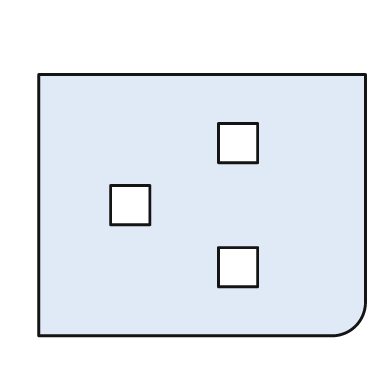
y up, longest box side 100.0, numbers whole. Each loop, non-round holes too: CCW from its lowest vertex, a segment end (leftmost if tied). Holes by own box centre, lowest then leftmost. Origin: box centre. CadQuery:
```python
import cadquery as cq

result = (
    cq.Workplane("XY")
    .moveTo(-50.0, -40.0)
    .lineTo(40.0, -40.0)
    .threePointArc((47.0, -37.0), (50.0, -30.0))
    .lineTo(50.0, 40.0)
    .lineTo(-50.0, 40.0)
    .close()
    .moveTo(5.0, -25.0)
    .lineTo(17.0, -25.0)
    .lineTo(17.0, -13.0)
    .lineTo(5.0, -13.0)
    .close()
    .moveTo(-28.0, -6.0)
    .lineTo(-16.0, -6.0)
    .lineTo(-16.0, 6.0)
    .lineTo(-28.0, 6.0)
    .close()
    .moveTo(5.0, 13.0)
    .lineTo(17.0, 13.0)
    .lineTo(17.0, 25.0)
    .lineTo(5.0, 25.0)
    .close()
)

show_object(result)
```